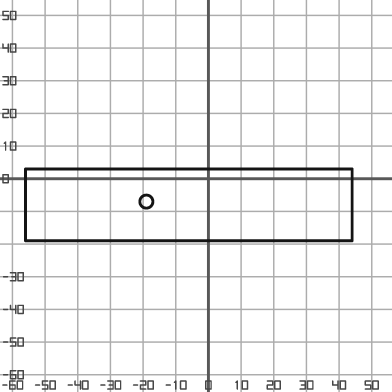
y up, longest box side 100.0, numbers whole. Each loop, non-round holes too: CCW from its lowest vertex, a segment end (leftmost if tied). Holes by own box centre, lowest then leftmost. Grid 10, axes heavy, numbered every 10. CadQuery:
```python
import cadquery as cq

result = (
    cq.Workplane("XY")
    .moveTo(-56.0, -19.0)
    .lineTo(44.0, -19.0)
    .lineTo(44.0, 3.0)
    .lineTo(-56.0, 3.0)
    .close()
    .moveTo(-19.0, -7.0)
    .circle(2.0)
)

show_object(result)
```